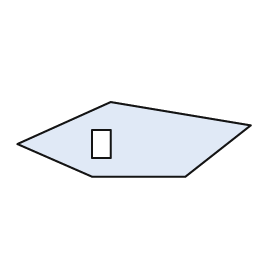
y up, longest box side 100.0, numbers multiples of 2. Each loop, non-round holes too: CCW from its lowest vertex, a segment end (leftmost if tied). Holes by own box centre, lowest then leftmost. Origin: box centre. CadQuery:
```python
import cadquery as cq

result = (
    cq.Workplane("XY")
    .moveTo(-18.0, -16.0)
    .lineTo(22.0, -16.0)
    .lineTo(50.0, 6.0)
    .lineTo(-10.0, 16.0)
    .lineTo(-50.0, -2.0)
    .close()
    .moveTo(-18.0, -8.0)
    .lineTo(-10.0, -8.0)
    .lineTo(-10.0, 4.0)
    .lineTo(-18.0, 4.0)
    .close()
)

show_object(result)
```